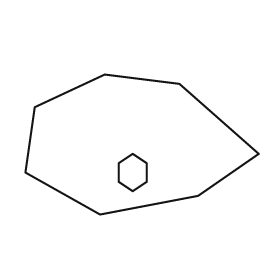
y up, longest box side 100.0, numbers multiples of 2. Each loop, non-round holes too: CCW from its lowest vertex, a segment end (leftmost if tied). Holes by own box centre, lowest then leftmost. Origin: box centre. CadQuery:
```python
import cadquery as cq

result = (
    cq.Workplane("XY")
    .moveTo(-18.0, -30.0)
    .lineTo(24.0, -22.0)
    .lineTo(50.0, -4.0)
    .lineTo(16.0, 26.0)
    .lineTo(-16.0, 30.0)
    .lineTo(-46.0, 16.0)
    .lineTo(-50.0, -12.0)
    .close()
    .moveTo(-4.0, -20.0)
    .lineTo(2.0, -16.0)
    .lineTo(2.0, -8.0)
    .lineTo(-4.0, -4.0)
    .lineTo(-10.0, -8.0)
    .lineTo(-10.0, -16.0)
    .close()
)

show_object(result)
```